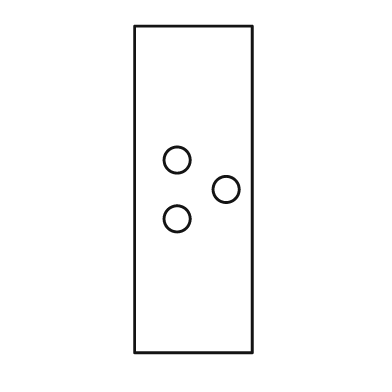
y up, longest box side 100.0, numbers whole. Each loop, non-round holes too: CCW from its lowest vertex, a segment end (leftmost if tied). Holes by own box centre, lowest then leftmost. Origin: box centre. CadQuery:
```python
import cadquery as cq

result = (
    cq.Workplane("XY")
    .moveTo(-18.0, -50.0)
    .lineTo(18.0, -50.0)
    .lineTo(18.0, 50.0)
    .lineTo(-18.0, 50.0)
    .close()
    .moveTo(-5.0, -9.0)
    .circle(4.0)
    .moveTo(10.0, 0.0)
    .circle(4.0)
    .moveTo(-5.0, 9.0)
    .circle(4.0)
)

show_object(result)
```